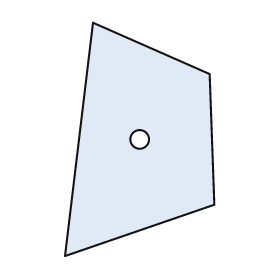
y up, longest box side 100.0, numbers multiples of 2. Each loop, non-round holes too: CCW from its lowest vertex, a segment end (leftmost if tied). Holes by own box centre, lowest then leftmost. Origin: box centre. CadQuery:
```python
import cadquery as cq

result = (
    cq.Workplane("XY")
    .moveTo(-32.0, -50.0)
    .lineTo(32.0, -28.0)
    .lineTo(30.0, 28.0)
    .lineTo(-20.0, 50.0)
    .close()
    .moveTo(0.0, 0.0)
    .circle(4.0)
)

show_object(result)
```